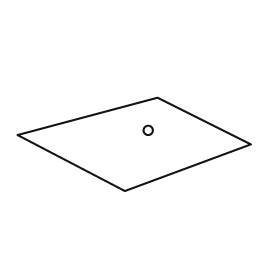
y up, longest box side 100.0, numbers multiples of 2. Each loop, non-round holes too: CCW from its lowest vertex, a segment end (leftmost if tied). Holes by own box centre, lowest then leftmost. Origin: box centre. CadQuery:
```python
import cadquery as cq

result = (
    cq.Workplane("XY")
    .moveTo(-4.0, -20.0)
    .lineTo(50.0, 0.0)
    .lineTo(10.0, 20.0)
    .lineTo(-50.0, 4.0)
    .close()
    .moveTo(6.0, 6.0)
    .circle(2.0)
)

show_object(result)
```